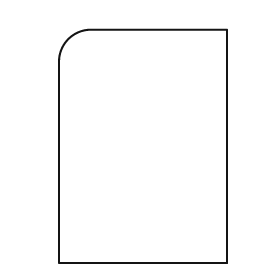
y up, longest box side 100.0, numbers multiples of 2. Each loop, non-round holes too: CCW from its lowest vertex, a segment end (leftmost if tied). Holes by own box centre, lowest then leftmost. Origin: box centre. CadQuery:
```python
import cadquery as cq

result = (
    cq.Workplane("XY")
    .moveTo(-36.0, -50.0)
    .lineTo(36.0, -50.0)
    .lineTo(36.0, 50.0)
    .lineTo(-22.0, 50.0)
    .threePointArc((-32.0, 46.0), (-36.0, 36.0))
    .close()
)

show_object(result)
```